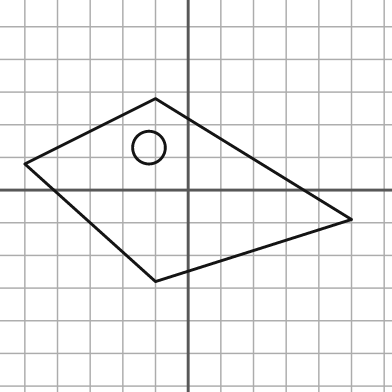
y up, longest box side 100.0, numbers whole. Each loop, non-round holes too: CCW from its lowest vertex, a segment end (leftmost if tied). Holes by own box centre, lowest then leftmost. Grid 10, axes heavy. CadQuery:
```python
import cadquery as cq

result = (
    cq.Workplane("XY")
    .moveTo(-10.0, -28.0)
    .lineTo(50.0, -9.0)
    .lineTo(-10.0, 28.0)
    .lineTo(-50.0, 8.0)
    .close()
    .moveTo(-12.0, 13.0)
    .circle(5.0)
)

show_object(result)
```